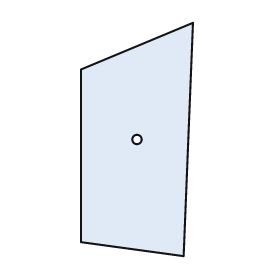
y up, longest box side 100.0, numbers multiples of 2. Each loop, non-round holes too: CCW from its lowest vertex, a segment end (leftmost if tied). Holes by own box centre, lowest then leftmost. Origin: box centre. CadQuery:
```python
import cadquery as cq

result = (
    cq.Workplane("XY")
    .moveTo(20.0, -50.0)
    .lineTo(24.0, 50.0)
    .lineTo(-24.0, 30.0)
    .lineTo(-24.0, -44.0)
    .close()
    .moveTo(0.0, 0.0)
    .circle(2.0)
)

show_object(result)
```